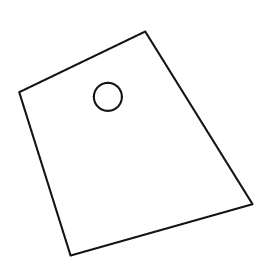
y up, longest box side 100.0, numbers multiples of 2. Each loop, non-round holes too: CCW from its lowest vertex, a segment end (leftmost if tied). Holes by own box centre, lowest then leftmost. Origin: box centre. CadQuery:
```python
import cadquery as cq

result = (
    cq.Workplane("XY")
    .moveTo(-28.0, -48.0)
    .lineTo(50.0, -26.0)
    .lineTo(4.0, 48.0)
    .lineTo(-50.0, 22.0)
    .close()
    .moveTo(-12.0, 20.0)
    .circle(6.0)
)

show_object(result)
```